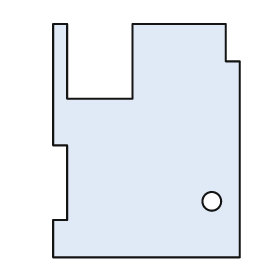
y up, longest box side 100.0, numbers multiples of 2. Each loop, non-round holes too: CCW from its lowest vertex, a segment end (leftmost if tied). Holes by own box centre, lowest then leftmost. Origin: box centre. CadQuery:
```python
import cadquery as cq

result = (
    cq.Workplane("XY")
    .moveTo(-40.0, -50.0)
    .lineTo(40.0, -50.0)
    .lineTo(40.0, 34.0)
    .lineTo(34.0, 34.0)
    .lineTo(34.0, 50.0)
    .lineTo(-6.0, 50.0)
    .lineTo(-6.0, 18.0)
    .lineTo(-34.0, 18.0)
    .lineTo(-34.0, 50.0)
    .lineTo(-40.0, 50.0)
    .lineTo(-40.0, -2.0)
    .lineTo(-34.0, -2.0)
    .lineTo(-34.0, -34.0)
    .lineTo(-40.0, -34.0)
    .close()
    .moveTo(28.0, -26.0)
    .circle(4.0)
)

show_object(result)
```